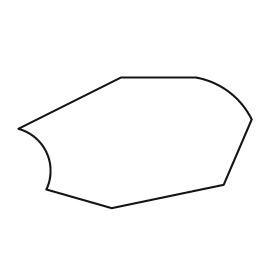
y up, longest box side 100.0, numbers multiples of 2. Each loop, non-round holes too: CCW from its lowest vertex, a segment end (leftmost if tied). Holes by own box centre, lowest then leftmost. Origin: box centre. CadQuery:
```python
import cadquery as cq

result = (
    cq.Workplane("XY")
    .moveTo(-10.0, -28.0)
    .lineTo(38.0, -18.0)
    .lineTo(50.0, 10.0)
    .threePointArc((40.0, 22.0), (26.0, 28.0))
    .lineTo(-6.0, 28.0)
    .lineTo(-50.0, 6.0)
    .threePointArc((-38.0, -4.0), (-38.0, -20.0))
    .close()
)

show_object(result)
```